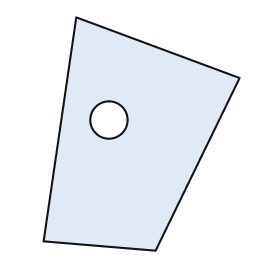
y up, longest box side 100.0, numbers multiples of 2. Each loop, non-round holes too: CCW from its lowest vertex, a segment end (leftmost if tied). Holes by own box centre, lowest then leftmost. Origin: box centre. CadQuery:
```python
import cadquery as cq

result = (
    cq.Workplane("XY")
    .moveTo(6.0, -50.0)
    .lineTo(42.0, 24.0)
    .lineTo(-28.0, 50.0)
    .lineTo(-42.0, -46.0)
    .close()
    .moveTo(-14.0, 6.0)
    .circle(8.0)
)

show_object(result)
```